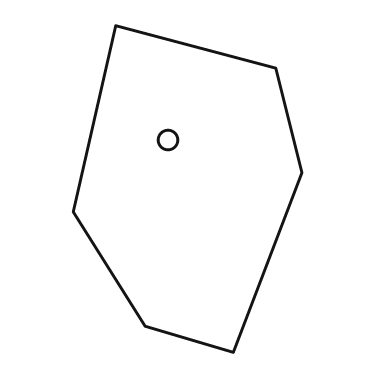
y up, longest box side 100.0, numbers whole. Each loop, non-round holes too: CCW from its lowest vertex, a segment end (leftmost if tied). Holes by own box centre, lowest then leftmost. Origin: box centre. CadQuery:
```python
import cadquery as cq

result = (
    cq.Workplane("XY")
    .moveTo(14.0, -50.0)
    .lineTo(35.0, 5.0)
    .lineTo(27.0, 37.0)
    .lineTo(-22.0, 50.0)
    .lineTo(-35.0, -7.0)
    .lineTo(-13.0, -42.0)
    .close()
    .moveTo(-6.0, 15.0)
    .circle(3.0)
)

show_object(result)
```